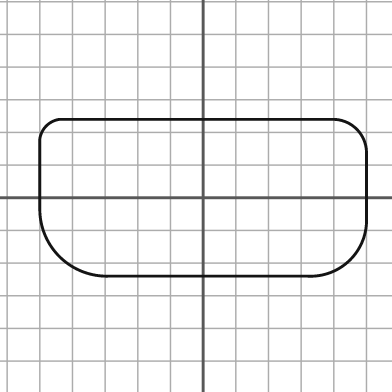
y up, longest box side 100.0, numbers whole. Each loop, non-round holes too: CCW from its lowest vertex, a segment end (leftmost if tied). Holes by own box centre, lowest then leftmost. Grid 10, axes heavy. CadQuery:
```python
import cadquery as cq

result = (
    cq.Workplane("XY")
    .moveTo(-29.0, -24.0)
    .lineTo(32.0, -24.0)
    .threePointArc((45.0, -19.0), (50.0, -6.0))
    .lineTo(50.0, 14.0)
    .threePointArc((47.0, 21.0), (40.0, 24.0))
    .lineTo(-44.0, 24.0)
    .threePointArc((-48.0, 22.0), (-50.0, 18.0))
    .lineTo(-50.0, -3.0)
    .threePointArc((-44.0, -18.0), (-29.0, -24.0))
    .close()
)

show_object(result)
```